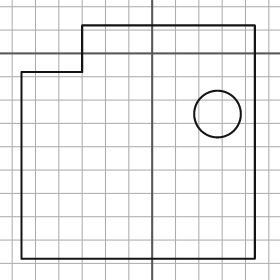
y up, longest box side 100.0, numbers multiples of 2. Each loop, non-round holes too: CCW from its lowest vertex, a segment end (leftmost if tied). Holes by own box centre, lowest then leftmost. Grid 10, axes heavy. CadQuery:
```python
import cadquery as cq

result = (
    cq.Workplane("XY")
    .moveTo(-56.0, -88.0)
    .lineTo(44.0, -88.0)
    .lineTo(44.0, 12.0)
    .lineTo(-30.0, 12.0)
    .lineTo(-30.0, -8.0)
    .lineTo(-56.0, -8.0)
    .close()
    .moveTo(28.0, -26.0)
    .circle(10.0)
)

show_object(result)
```